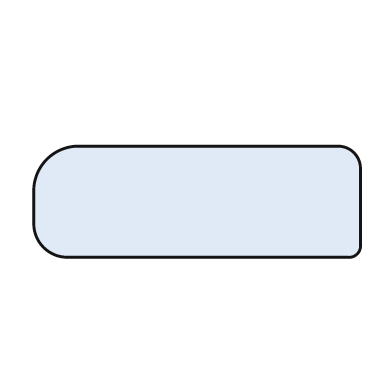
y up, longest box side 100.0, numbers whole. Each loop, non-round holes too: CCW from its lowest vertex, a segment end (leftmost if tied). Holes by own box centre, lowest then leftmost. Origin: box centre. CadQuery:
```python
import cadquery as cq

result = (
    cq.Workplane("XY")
    .moveTo(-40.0, -17.0)
    .lineTo(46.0, -17.0)
    .threePointArc((49.0, -16.0), (50.0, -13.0))
    .lineTo(50.0, 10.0)
    .threePointArc((48.0, 15.0), (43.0, 17.0))
    .lineTo(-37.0, 17.0)
    .threePointArc((-46.0, 13.0), (-50.0, 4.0))
    .lineTo(-50.0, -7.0)
    .threePointArc((-47.0, -14.0), (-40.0, -17.0))
    .close()
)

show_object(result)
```